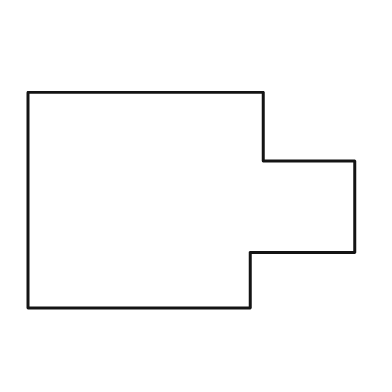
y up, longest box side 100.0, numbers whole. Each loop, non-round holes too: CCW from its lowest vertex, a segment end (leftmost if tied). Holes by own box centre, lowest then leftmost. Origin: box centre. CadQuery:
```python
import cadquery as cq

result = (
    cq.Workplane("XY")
    .moveTo(-50.0, -33.0)
    .lineTo(18.0, -33.0)
    .lineTo(18.0, -16.0)
    .lineTo(50.0, -16.0)
    .lineTo(50.0, 12.0)
    .lineTo(22.0, 12.0)
    .lineTo(22.0, 33.0)
    .lineTo(-50.0, 33.0)
    .close()
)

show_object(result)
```